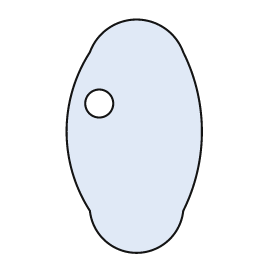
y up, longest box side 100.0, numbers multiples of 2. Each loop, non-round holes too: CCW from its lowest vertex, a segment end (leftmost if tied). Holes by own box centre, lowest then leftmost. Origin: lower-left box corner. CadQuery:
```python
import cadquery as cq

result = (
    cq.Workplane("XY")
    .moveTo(10.0, 18.0)
    .threePointArc((30.0, 0.0), (50.0, 18.0))
    .threePointArc((58.0, 52.0), (50.0, 86.0))
    .threePointArc((30.0, 100.0), (10.0, 86.0))
    .threePointArc((0.0, 52.0), (10.0, 18.0))
    .close()
    .moveTo(14.0, 64.0)
    .circle(6.0)
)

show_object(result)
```